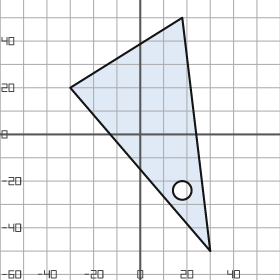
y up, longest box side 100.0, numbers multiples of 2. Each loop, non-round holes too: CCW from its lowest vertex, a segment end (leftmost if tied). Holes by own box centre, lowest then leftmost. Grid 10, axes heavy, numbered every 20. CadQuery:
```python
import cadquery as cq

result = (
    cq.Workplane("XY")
    .moveTo(30.0, -50.0)
    .lineTo(18.0, 50.0)
    .lineTo(-30.0, 20.0)
    .close()
    .moveTo(18.0, -24.0)
    .circle(4.0)
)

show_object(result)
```